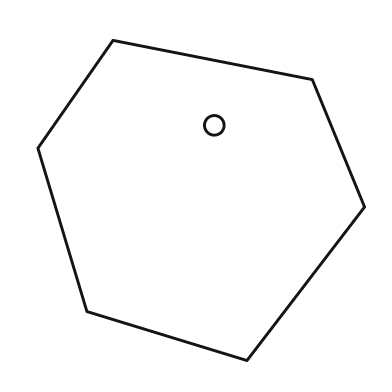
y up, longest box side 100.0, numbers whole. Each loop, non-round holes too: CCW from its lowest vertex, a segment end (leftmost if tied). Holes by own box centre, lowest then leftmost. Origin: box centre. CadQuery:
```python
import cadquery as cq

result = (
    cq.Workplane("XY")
    .moveTo(14.0, -49.0)
    .lineTo(50.0, -2.0)
    .lineTo(34.0, 37.0)
    .lineTo(-27.0, 49.0)
    .lineTo(-50.0, 16.0)
    .lineTo(-35.0, -34.0)
    .close()
    .moveTo(4.0, 23.0)
    .circle(3.0)
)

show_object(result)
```